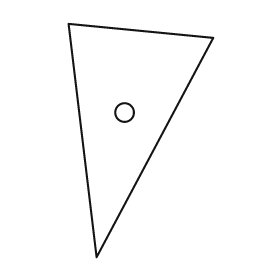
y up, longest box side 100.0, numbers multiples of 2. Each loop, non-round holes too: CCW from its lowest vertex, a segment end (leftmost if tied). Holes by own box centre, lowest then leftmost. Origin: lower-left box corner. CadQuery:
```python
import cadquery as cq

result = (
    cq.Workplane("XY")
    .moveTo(12.0, 0.0)
    .lineTo(62.0, 94.0)
    .lineTo(0.0, 100.0)
    .close()
    .moveTo(24.0, 62.0)
    .circle(4.0)
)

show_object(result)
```